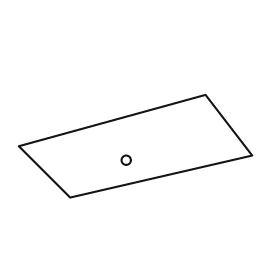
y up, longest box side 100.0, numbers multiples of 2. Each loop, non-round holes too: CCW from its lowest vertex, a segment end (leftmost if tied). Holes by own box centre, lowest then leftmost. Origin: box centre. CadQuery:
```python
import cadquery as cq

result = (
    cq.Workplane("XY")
    .moveTo(-28.0, -22.0)
    .lineTo(50.0, -4.0)
    .lineTo(30.0, 22.0)
    .lineTo(-50.0, 0.0)
    .close()
    .moveTo(-4.0, -6.0)
    .circle(2.0)
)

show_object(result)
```